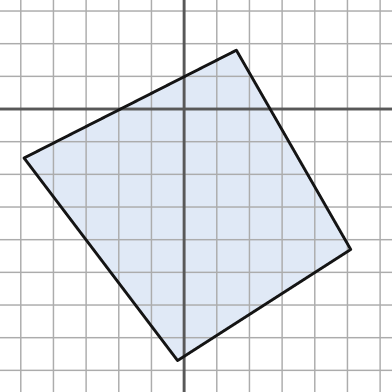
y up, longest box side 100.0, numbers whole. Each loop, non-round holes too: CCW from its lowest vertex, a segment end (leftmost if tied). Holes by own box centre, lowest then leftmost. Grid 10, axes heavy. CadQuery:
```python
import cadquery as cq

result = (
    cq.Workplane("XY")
    .moveTo(-2.0, -77.0)
    .lineTo(51.0, -43.0)
    .lineTo(16.0, 18.0)
    .lineTo(-49.0, -15.0)
    .close()
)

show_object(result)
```